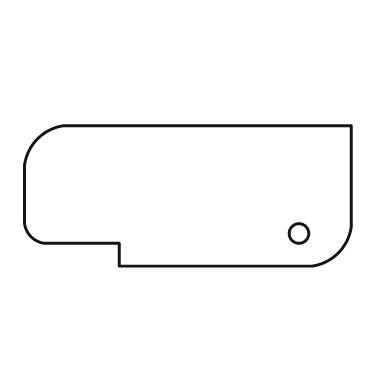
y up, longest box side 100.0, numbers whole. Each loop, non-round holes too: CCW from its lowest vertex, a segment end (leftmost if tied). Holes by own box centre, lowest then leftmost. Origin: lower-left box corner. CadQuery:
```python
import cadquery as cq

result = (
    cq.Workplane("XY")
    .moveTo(29.0, 0.0)
    .lineTo(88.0, 0.0)
    .threePointArc((96.0, 4.0), (100.0, 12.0))
    .lineTo(100.0, 43.0)
    .lineTo(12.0, 43.0)
    .threePointArc((4.0, 39.0), (0.0, 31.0))
    .lineTo(0.0, 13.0)
    .threePointArc((2.0, 9.0), (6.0, 7.0))
    .lineTo(29.0, 7.0)
    .close()
    .moveTo(84.0, 10.0)
    .circle(3.0)
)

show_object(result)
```